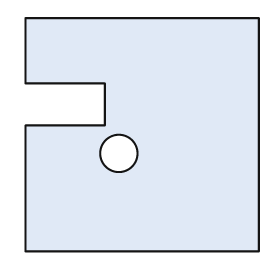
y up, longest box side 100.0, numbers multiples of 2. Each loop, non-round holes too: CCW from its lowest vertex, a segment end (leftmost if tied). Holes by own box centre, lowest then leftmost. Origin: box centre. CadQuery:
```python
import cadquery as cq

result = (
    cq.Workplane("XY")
    .moveTo(-50.0, -50.0)
    .lineTo(50.0, -50.0)
    .lineTo(50.0, 50.0)
    .lineTo(-50.0, 50.0)
    .lineTo(-50.0, 22.0)
    .lineTo(-16.0, 22.0)
    .lineTo(-16.0, 4.0)
    .lineTo(-50.0, 4.0)
    .close()
    .moveTo(-10.0, -8.0)
    .circle(8.0)
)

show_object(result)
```